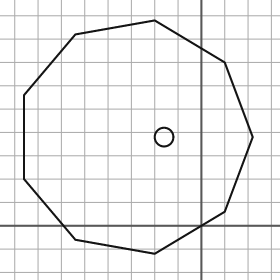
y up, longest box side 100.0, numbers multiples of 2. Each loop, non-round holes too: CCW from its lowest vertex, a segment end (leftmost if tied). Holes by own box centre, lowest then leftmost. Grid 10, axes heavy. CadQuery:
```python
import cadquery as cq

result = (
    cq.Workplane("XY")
    .moveTo(-20.0, -12.0)
    .lineTo(10.0, 6.0)
    .lineTo(22.0, 38.0)
    .lineTo(10.0, 70.0)
    .lineTo(-20.0, 88.0)
    .lineTo(-54.0, 82.0)
    .lineTo(-76.0, 56.0)
    .lineTo(-76.0, 20.0)
    .lineTo(-54.0, -6.0)
    .close()
    .moveTo(-16.0, 38.0)
    .circle(4.0)
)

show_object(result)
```